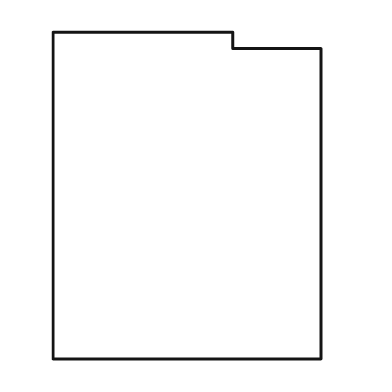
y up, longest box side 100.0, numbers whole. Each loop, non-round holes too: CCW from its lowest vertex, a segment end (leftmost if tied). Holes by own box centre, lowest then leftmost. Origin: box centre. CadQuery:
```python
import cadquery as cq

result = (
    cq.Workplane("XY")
    .moveTo(-41.0, -50.0)
    .lineTo(41.0, -50.0)
    .lineTo(41.0, 45.0)
    .lineTo(14.0, 45.0)
    .lineTo(14.0, 50.0)
    .lineTo(-41.0, 50.0)
    .close()
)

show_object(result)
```